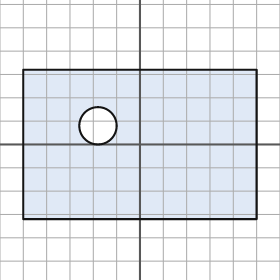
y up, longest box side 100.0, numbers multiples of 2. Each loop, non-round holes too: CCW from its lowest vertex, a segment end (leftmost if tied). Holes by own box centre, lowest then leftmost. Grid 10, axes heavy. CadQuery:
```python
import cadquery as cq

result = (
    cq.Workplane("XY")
    .moveTo(-50.0, -32.0)
    .lineTo(50.0, -32.0)
    .lineTo(50.0, 32.0)
    .lineTo(-50.0, 32.0)
    .close()
    .moveTo(-18.0, 8.0)
    .circle(8.0)
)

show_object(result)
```